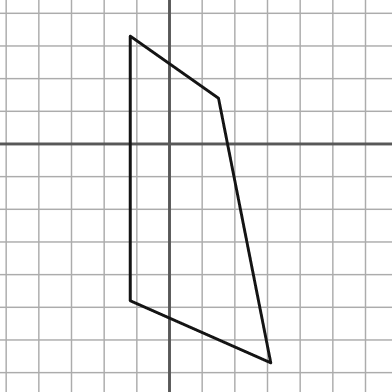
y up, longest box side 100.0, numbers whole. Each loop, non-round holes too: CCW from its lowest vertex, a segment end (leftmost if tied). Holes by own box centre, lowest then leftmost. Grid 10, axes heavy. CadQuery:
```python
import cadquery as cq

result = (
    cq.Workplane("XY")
    .moveTo(31.0, -67.0)
    .lineTo(15.0, 14.0)
    .lineTo(-12.0, 33.0)
    .lineTo(-12.0, -48.0)
    .close()
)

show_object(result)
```